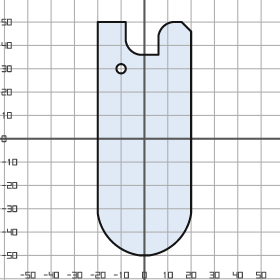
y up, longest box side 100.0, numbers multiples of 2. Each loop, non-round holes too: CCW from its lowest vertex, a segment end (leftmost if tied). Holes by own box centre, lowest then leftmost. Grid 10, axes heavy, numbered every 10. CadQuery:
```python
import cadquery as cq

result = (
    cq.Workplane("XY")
    .moveTo(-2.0, -50.0)
    .lineTo(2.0, -50.0)
    .threePointArc((14.0, -44.0), (20.0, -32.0))
    .lineTo(20.0, 46.0)
    .lineTo(16.0, 50.0)
    .lineTo(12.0, 50.0)
    .threePointArc((8.0, 48.0), (6.0, 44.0))
    .lineTo(6.0, 36.0)
    .lineTo(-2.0, 36.0)
    .threePointArc((-6.0, 38.0), (-8.0, 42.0))
    .lineTo(-8.0, 50.0)
    .lineTo(-20.0, 50.0)
    .lineTo(-20.0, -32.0)
    .threePointArc((-14.0, -44.0), (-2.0, -50.0))
    .close()
    .moveTo(-10.0, 30.0)
    .circle(2.0)
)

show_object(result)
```